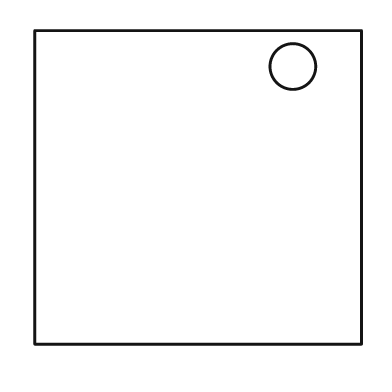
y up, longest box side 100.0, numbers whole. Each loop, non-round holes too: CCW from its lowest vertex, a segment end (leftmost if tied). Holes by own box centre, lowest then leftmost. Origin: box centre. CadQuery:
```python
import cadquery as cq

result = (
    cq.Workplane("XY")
    .moveTo(-50.0, -48.0)
    .lineTo(50.0, -48.0)
    .lineTo(50.0, 48.0)
    .lineTo(-50.0, 48.0)
    .close()
    .moveTo(29.0, 37.0)
    .circle(7.0)
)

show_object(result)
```